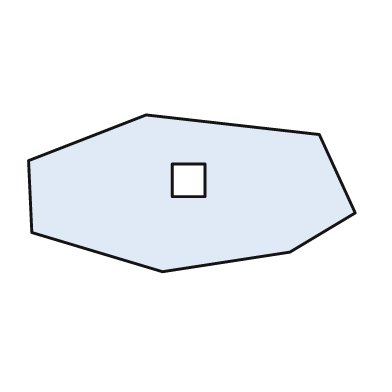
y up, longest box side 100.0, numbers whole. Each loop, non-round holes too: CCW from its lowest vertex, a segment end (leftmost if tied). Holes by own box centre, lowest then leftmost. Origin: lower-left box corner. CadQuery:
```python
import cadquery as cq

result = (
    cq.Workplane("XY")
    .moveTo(41.0, 0.0)
    .lineTo(80.0, 6.0)
    .lineTo(100.0, 18.0)
    .lineTo(89.0, 42.0)
    .lineTo(36.0, 48.0)
    .lineTo(0.0, 34.0)
    .lineTo(1.0, 12.0)
    .close()
    .moveTo(44.0, 23.0)
    .lineTo(54.0, 23.0)
    .lineTo(54.0, 33.0)
    .lineTo(44.0, 33.0)
    .close()
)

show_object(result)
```